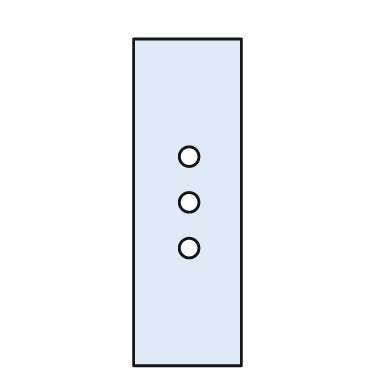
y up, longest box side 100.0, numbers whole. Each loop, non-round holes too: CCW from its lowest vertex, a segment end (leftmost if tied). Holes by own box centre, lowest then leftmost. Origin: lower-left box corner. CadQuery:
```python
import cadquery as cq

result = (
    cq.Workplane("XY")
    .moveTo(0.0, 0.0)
    .lineTo(33.0, 0.0)
    .lineTo(33.0, 100.0)
    .lineTo(0.0, 100.0)
    .close()
    .moveTo(17.0, 36.0)
    .circle(3.0)
    .moveTo(17.0, 50.0)
    .circle(3.0)
    .moveTo(17.0, 64.0)
    .circle(3.0)
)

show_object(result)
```